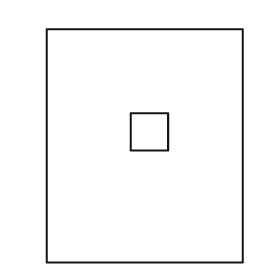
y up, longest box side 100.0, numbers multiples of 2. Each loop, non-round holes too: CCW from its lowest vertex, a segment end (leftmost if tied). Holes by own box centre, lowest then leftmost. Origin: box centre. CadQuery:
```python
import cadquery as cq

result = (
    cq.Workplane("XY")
    .moveTo(-42.0, -50.0)
    .lineTo(42.0, -50.0)
    .lineTo(42.0, 50.0)
    .lineTo(-42.0, 50.0)
    .close()
    .moveTo(-6.0, -2.0)
    .lineTo(10.0, -2.0)
    .lineTo(10.0, 14.0)
    .lineTo(-6.0, 14.0)
    .close()
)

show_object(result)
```